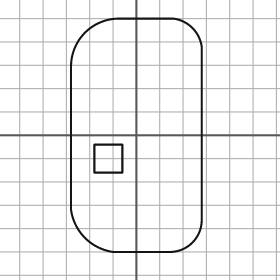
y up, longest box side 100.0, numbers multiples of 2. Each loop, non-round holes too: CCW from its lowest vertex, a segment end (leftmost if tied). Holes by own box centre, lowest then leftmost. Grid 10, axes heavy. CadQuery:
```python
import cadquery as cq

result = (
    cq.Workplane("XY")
    .moveTo(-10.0, -50.0)
    .lineTo(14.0, -50.0)
    .threePointArc((24.0, -46.0), (28.0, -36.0))
    .lineTo(28.0, 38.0)
    .threePointArc((24.0, 46.0), (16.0, 50.0))
    .lineTo(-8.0, 50.0)
    .threePointArc((-22.0, 44.0), (-28.0, 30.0))
    .lineTo(-28.0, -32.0)
    .threePointArc((-22.0, -44.0), (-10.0, -50.0))
    .close()
    .moveTo(-18.0, -16.0)
    .lineTo(-6.0, -16.0)
    .lineTo(-6.0, -4.0)
    .lineTo(-18.0, -4.0)
    .close()
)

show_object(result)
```